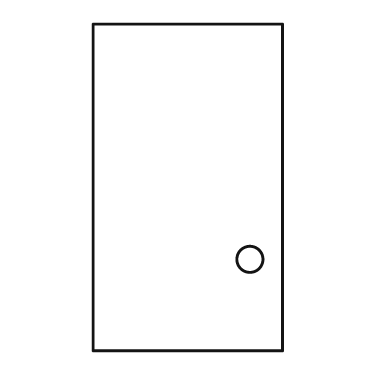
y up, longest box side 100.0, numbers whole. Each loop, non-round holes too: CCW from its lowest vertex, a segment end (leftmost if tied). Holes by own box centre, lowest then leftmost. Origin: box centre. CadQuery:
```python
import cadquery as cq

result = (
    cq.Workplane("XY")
    .moveTo(-29.0, -50.0)
    .lineTo(29.0, -50.0)
    .lineTo(29.0, 50.0)
    .lineTo(-29.0, 50.0)
    .close()
    .moveTo(19.0, -22.0)
    .circle(4.0)
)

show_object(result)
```